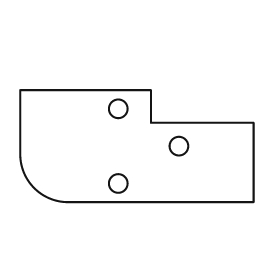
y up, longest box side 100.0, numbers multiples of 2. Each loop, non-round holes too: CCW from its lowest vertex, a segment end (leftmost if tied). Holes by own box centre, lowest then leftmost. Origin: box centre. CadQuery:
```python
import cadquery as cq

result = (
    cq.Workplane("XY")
    .moveTo(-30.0, -24.0)
    .lineTo(50.0, -24.0)
    .lineTo(50.0, 10.0)
    .lineTo(6.0, 10.0)
    .lineTo(6.0, 24.0)
    .lineTo(-50.0, 24.0)
    .lineTo(-50.0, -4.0)
    .threePointArc((-44.0, -18.0), (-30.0, -24.0))
    .close()
    .moveTo(-8.0, -16.0)
    .circle(4.0)
    .moveTo(18.0, 0.0)
    .circle(4.0)
    .moveTo(-8.0, 16.0)
    .circle(4.0)
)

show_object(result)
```